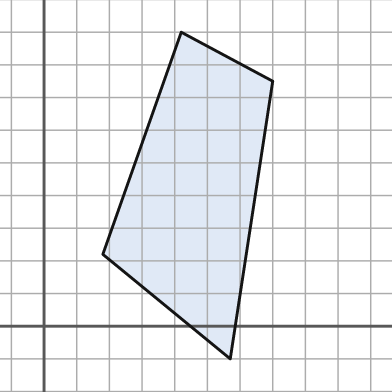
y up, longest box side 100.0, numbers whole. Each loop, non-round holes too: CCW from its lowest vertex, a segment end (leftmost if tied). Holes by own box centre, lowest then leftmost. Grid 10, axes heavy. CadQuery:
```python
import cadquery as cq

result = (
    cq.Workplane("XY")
    .moveTo(57.0, -10.0)
    .lineTo(70.0, 75.0)
    .lineTo(42.0, 90.0)
    .lineTo(18.0, 22.0)
    .close()
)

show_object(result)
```